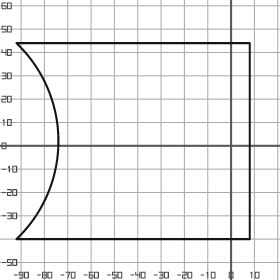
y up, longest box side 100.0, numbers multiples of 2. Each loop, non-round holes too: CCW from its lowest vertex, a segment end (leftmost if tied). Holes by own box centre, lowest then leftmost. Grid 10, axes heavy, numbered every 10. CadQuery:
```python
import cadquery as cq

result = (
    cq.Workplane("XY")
    .moveTo(-92.0, -40.0)
    .lineTo(8.0, -40.0)
    .lineTo(8.0, 44.0)
    .lineTo(-92.0, 44.0)
    .threePointArc((-74.0, 2.0), (-92.0, -40.0))
    .close()
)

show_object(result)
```